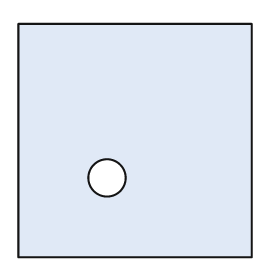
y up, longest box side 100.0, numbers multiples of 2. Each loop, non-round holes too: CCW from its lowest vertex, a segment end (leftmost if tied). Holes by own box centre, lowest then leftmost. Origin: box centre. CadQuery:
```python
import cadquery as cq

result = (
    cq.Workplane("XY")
    .moveTo(-50.0, -50.0)
    .lineTo(50.0, -50.0)
    .lineTo(50.0, 50.0)
    .lineTo(-50.0, 50.0)
    .close()
    .moveTo(-12.0, -16.0)
    .circle(8.0)
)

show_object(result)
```